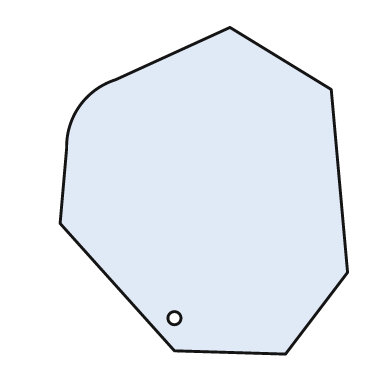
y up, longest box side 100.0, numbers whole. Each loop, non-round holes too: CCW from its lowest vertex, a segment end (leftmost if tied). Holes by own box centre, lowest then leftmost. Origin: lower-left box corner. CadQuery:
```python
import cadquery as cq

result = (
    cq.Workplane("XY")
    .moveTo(69.0, 0.0)
    .lineTo(88.0, 25.0)
    .lineTo(83.0, 81.0)
    .lineTo(52.0, 100.0)
    .lineTo(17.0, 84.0)
    .threePointArc((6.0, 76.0), (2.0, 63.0))
    .lineTo(0.0, 40.0)
    .lineTo(35.0, 1.0)
    .close()
    .moveTo(35.0, 11.0)
    .circle(2.0)
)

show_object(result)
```